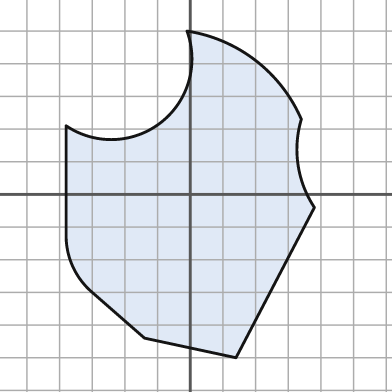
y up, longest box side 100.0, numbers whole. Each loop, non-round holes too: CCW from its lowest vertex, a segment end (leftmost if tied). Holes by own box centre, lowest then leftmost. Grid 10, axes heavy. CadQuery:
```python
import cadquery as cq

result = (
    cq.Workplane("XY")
    .moveTo(14.0, -50.0)
    .lineTo(38.0, -4.0)
    .threePointArc((33.0, 9.0), (34.0, 23.0))
    .threePointArc((20.0, 41.0), (-1.0, 50.0))
    .threePointArc((-9.0, 22.0), (-38.0, 21.0))
    .lineTo(-38.0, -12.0)
    .threePointArc((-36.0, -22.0), (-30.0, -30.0))
    .lineTo(-14.0, -44.0)
    .close()
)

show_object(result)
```